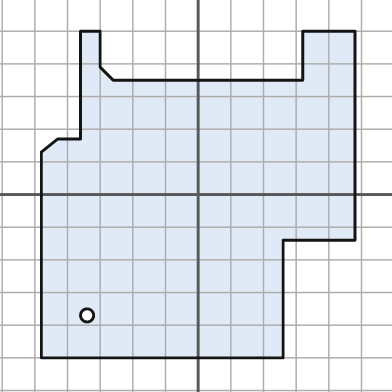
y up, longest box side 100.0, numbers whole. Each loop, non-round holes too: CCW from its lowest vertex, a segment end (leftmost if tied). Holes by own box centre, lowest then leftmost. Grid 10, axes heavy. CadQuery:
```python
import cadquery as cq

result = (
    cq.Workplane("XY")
    .moveTo(-48.0, -50.0)
    .lineTo(26.0, -50.0)
    .lineTo(26.0, -14.0)
    .lineTo(48.0, -14.0)
    .lineTo(48.0, 50.0)
    .lineTo(32.0, 50.0)
    .lineTo(32.0, 35.0)
    .lineTo(-26.0, 35.0)
    .lineTo(-30.0, 39.0)
    .lineTo(-30.0, 50.0)
    .lineTo(-36.0, 50.0)
    .lineTo(-36.0, 17.0)
    .lineTo(-43.0, 17.0)
    .lineTo(-48.0, 13.0)
    .close()
    .moveTo(-34.0, -37.0)
    .circle(2.0)
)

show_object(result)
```